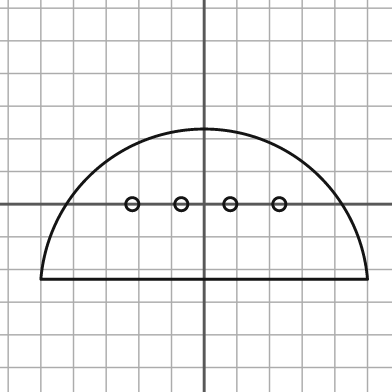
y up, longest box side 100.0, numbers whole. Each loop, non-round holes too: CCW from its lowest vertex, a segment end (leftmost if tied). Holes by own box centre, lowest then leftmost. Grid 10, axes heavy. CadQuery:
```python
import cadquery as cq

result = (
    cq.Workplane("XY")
    .moveTo(-50.0, -23.0)
    .lineTo(50.0, -23.0)
    .threePointArc((0.0, 23.0), (-50.0, -23.0))
    .close()
    .moveTo(-22.0, 0.0)
    .circle(2.0)
    .moveTo(-7.0, 0.0)
    .circle(2.0)
    .moveTo(8.0, 0.0)
    .circle(2.0)
    .moveTo(23.0, 0.0)
    .circle(2.0)
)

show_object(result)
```